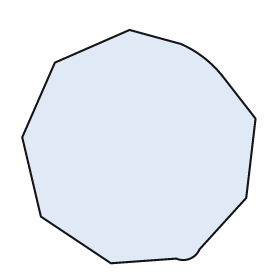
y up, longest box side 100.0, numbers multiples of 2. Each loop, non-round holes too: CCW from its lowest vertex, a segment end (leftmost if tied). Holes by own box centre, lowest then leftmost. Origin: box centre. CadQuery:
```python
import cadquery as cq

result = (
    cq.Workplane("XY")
    .moveTo(-12.0, -50.0)
    .lineTo(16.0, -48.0)
    .threePointArc((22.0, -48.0), (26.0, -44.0))
    .lineTo(46.0, -22.0)
    .lineTo(50.0, 12.0)
    .lineTo(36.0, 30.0)
    .threePointArc((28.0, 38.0), (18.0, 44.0))
    .lineTo(-4.0, 50.0)
    .lineTo(-36.0, 36.0)
    .lineTo(-50.0, 4.0)
    .lineTo(-42.0, -30.0)
    .close()
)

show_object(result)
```